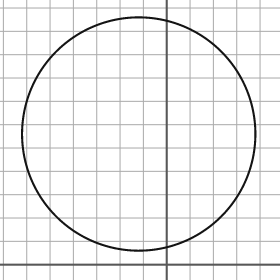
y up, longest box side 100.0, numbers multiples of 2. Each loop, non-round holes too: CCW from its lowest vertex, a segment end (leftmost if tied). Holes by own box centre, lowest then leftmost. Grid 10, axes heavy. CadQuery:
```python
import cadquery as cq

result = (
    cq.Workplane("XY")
    .moveTo(-12.0, 56.0)
    .circle(50.0)
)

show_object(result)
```